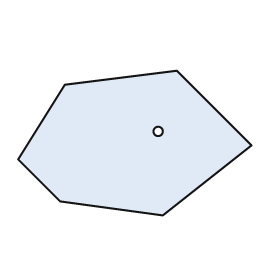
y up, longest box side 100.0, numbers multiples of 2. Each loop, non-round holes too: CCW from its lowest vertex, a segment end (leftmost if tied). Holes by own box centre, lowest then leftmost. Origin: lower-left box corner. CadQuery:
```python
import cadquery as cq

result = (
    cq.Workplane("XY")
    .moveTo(62.0, 0.0)
    .lineTo(100.0, 30.0)
    .lineTo(68.0, 62.0)
    .lineTo(20.0, 56.0)
    .lineTo(0.0, 24.0)
    .lineTo(18.0, 6.0)
    .close()
    .moveTo(60.0, 36.0)
    .circle(2.0)
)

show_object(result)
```